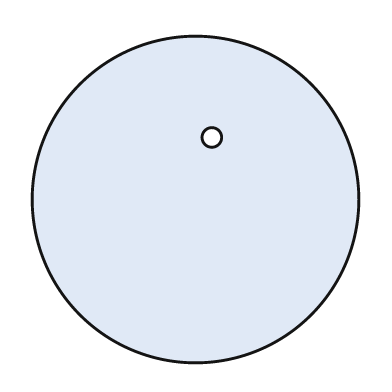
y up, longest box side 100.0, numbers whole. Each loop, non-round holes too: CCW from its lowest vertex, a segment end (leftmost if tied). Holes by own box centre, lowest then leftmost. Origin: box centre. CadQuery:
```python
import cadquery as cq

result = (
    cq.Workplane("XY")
    .moveTo(0.0, 0.0)
    .circle(50.0)
    .moveTo(5.0, 19.0)
    .circle(3.0)
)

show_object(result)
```